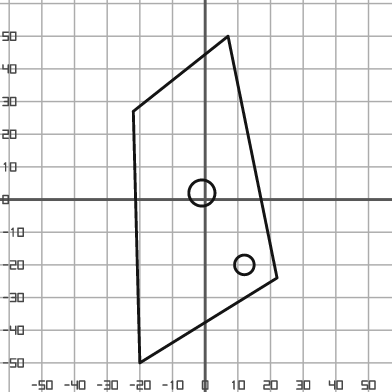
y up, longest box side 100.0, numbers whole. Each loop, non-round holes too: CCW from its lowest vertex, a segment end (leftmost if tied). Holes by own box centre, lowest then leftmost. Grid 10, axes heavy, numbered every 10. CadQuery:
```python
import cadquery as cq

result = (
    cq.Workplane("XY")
    .moveTo(-20.0, -50.0)
    .lineTo(22.0, -24.0)
    .lineTo(7.0, 50.0)
    .lineTo(-22.0, 27.0)
    .close()
    .moveTo(12.0, -20.0)
    .circle(3.0)
    .moveTo(-1.0, 2.0)
    .circle(4.0)
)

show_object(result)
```